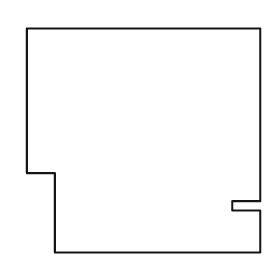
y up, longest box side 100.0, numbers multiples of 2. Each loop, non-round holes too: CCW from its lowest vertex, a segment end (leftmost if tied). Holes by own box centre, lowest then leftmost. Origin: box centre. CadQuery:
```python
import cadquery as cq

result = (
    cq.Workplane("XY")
    .moveTo(-38.0, -48.0)
    .lineTo(50.0, -48.0)
    .lineTo(50.0, -30.0)
    .lineTo(38.0, -30.0)
    .lineTo(38.0, -26.0)
    .lineTo(50.0, -26.0)
    .lineTo(50.0, 48.0)
    .lineTo(-50.0, 48.0)
    .lineTo(-50.0, -14.0)
    .lineTo(-38.0, -14.0)
    .close()
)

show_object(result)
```